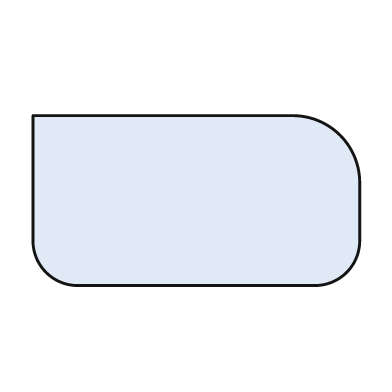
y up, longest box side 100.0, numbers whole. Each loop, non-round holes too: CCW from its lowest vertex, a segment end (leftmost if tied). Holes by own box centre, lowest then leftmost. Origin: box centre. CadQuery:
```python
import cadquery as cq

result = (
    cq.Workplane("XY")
    .moveTo(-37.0, -26.0)
    .lineTo(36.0, -26.0)
    .threePointArc((46.0, -22.0), (50.0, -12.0))
    .lineTo(50.0, 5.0)
    .threePointArc((44.0, 20.0), (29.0, 26.0))
    .lineTo(-50.0, 26.0)
    .lineTo(-50.0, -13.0)
    .threePointArc((-46.0, -22.0), (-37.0, -26.0))
    .close()
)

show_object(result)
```